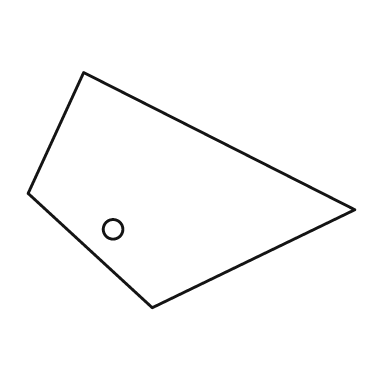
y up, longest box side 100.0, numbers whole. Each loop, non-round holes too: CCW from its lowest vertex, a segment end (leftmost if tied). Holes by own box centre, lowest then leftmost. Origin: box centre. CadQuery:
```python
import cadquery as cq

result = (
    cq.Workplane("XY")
    .moveTo(-12.0, -36.0)
    .lineTo(50.0, -6.0)
    .lineTo(-33.0, 36.0)
    .lineTo(-50.0, -1.0)
    .close()
    .moveTo(-24.0, -12.0)
    .circle(3.0)
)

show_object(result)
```